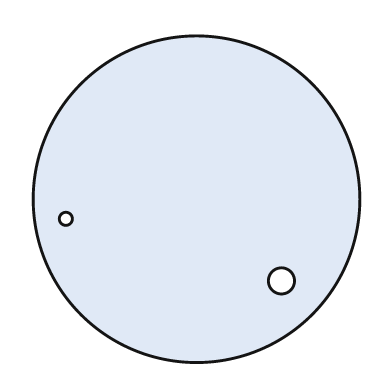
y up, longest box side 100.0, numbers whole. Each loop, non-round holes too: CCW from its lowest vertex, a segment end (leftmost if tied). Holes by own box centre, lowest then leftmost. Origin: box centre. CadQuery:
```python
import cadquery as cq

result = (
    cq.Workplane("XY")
    .moveTo(0.0, 0.0)
    .circle(50.0)
    .moveTo(26.0, -25.0)
    .circle(4.0)
    .moveTo(-40.0, -6.0)
    .circle(2.0)
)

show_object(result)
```